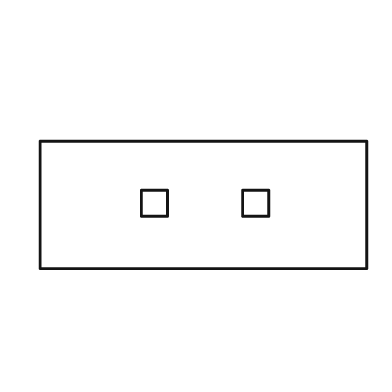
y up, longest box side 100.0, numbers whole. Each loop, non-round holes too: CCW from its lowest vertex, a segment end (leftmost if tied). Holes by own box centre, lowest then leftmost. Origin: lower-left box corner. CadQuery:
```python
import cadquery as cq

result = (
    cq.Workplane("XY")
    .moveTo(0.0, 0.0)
    .lineTo(100.0, 0.0)
    .lineTo(100.0, 39.0)
    .lineTo(0.0, 39.0)
    .close()
    .moveTo(31.0, 16.0)
    .lineTo(39.0, 16.0)
    .lineTo(39.0, 24.0)
    .lineTo(31.0, 24.0)
    .close()
    .moveTo(62.0, 16.0)
    .lineTo(70.0, 16.0)
    .lineTo(70.0, 24.0)
    .lineTo(62.0, 24.0)
    .close()
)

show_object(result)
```